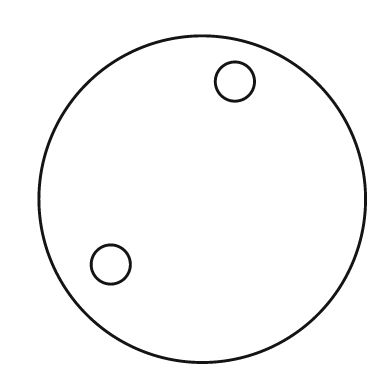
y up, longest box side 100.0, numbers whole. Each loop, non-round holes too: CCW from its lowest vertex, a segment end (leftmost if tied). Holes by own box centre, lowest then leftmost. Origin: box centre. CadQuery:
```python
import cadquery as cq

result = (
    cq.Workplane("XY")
    .moveTo(0.0, 0.0)
    .circle(50.0)
    .moveTo(-28.0, -20.0)
    .circle(6.0)
    .moveTo(10.0, 36.0)
    .circle(6.0)
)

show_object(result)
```